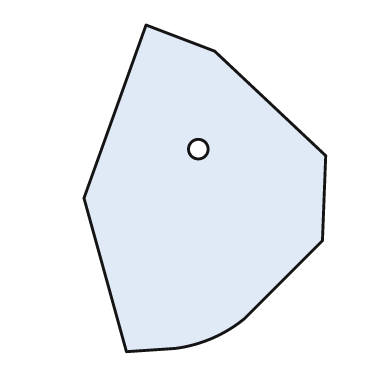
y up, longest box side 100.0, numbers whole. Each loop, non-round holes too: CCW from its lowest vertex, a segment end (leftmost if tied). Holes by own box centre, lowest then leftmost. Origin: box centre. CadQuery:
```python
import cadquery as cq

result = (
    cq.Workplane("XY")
    .moveTo(-24.0, -50.0)
    .lineTo(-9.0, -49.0)
    .threePointArc((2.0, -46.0), (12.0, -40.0))
    .lineTo(36.0, -16.0)
    .lineTo(37.0, 10.0)
    .lineTo(3.0, 42.0)
    .lineTo(-18.0, 50.0)
    .lineTo(-37.0, -3.0)
    .close()
    .moveTo(-2.0, 12.0)
    .circle(3.0)
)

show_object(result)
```